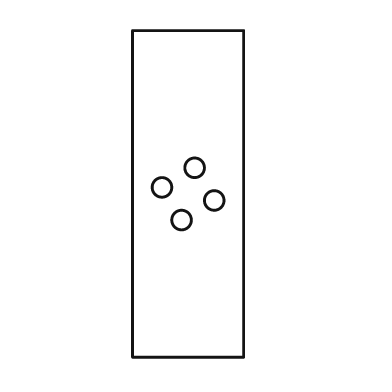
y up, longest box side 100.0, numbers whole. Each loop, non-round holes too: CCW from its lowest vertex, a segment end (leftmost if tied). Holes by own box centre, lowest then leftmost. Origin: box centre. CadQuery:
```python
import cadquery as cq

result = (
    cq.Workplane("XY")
    .moveTo(-17.0, -50.0)
    .lineTo(17.0, -50.0)
    .lineTo(17.0, 50.0)
    .lineTo(-17.0, 50.0)
    .close()
    .moveTo(-2.0, -8.0)
    .circle(3.0)
    .moveTo(8.0, -2.0)
    .circle(3.0)
    .moveTo(-8.0, 2.0)
    .circle(3.0)
    .moveTo(2.0, 8.0)
    .circle(3.0)
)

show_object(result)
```